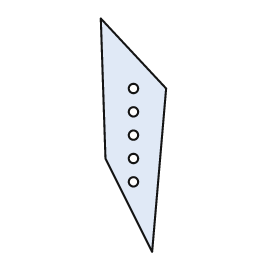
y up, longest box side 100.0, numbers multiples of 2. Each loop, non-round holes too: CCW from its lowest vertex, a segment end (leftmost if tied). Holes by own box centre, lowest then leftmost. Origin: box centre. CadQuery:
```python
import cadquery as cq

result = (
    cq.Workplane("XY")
    .moveTo(8.0, -50.0)
    .lineTo(14.0, 20.0)
    .lineTo(-14.0, 50.0)
    .lineTo(-12.0, -10.0)
    .close()
    .moveTo(0.0, -20.0)
    .circle(2.0)
    .moveTo(0.0, -10.0)
    .circle(2.0)
    .moveTo(0.0, 0.0)
    .circle(2.0)
    .moveTo(0.0, 10.0)
    .circle(2.0)
    .moveTo(0.0, 20.0)
    .circle(2.0)
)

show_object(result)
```